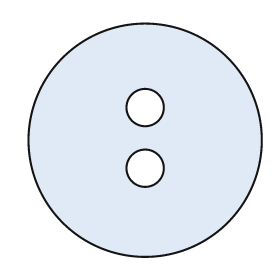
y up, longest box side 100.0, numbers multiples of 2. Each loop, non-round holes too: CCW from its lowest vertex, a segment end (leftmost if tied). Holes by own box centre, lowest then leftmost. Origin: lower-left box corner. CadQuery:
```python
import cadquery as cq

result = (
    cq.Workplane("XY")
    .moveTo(50.0, 50.0)
    .circle(50.0)
    .moveTo(50.0, 38.0)
    .circle(8.0)
    .moveTo(50.0, 64.0)
    .circle(8.0)
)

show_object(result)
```